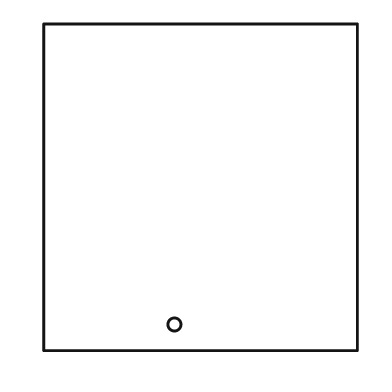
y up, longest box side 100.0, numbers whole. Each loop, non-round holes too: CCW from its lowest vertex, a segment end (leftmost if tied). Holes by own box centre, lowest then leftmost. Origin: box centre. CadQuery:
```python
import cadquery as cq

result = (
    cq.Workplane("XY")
    .moveTo(-48.0, -50.0)
    .lineTo(48.0, -50.0)
    .lineTo(48.0, 50.0)
    .lineTo(-48.0, 50.0)
    .close()
    .moveTo(-8.0, -42.0)
    .circle(2.0)
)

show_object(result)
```